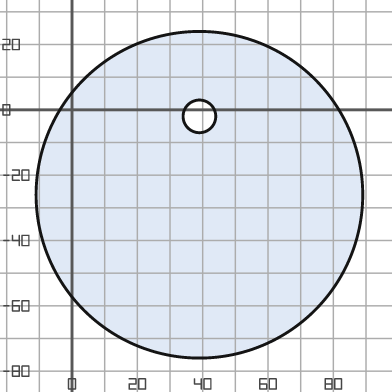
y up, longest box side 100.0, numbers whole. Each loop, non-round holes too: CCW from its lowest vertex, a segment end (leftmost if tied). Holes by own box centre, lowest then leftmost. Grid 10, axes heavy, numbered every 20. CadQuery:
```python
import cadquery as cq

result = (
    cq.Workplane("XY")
    .moveTo(39.0, -26.0)
    .circle(50.0)
    .moveTo(39.0, -2.0)
    .circle(5.0)
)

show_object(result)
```